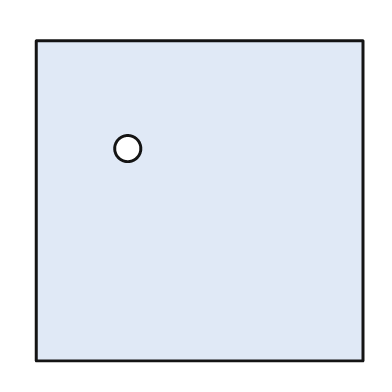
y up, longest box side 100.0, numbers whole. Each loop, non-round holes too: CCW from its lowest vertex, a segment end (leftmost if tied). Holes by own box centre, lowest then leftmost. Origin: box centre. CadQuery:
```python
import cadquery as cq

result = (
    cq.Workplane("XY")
    .moveTo(-50.0, -49.0)
    .lineTo(50.0, -49.0)
    .lineTo(50.0, 49.0)
    .lineTo(-50.0, 49.0)
    .close()
    .moveTo(-22.0, 16.0)
    .circle(4.0)
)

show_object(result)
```